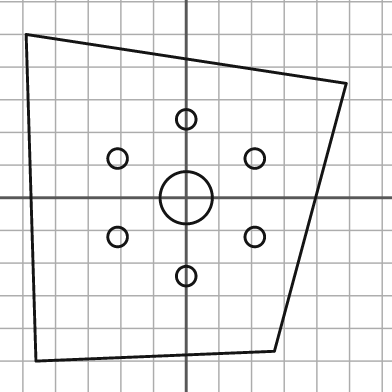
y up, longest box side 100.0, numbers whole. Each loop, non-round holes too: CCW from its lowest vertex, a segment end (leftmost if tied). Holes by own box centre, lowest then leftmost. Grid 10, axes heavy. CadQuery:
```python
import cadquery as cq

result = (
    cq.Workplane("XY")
    .moveTo(-46.0, -50.0)
    .lineTo(27.0, -47.0)
    .lineTo(49.0, 35.0)
    .lineTo(-49.0, 50.0)
    .close()
    .moveTo(0.0, -24.0)
    .circle(3.0)
    .moveTo(-21.0, -12.0)
    .circle(3.0)
    .moveTo(21.0, -12.0)
    .circle(3.0)
    .moveTo(0.0, 0.0)
    .circle(8.0)
    .moveTo(-21.0, 12.0)
    .circle(3.0)
    .moveTo(21.0, 12.0)
    .circle(3.0)
    .moveTo(0.0, 24.0)
    .circle(3.0)
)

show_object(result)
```